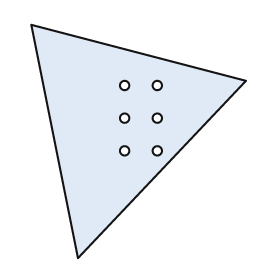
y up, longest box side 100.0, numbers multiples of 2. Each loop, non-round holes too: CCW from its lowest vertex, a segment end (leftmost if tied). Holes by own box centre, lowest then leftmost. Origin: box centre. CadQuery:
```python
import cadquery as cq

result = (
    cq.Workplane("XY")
    .moveTo(-26.0, -50.0)
    .lineTo(46.0, 26.0)
    .lineTo(-46.0, 50.0)
    .close()
    .moveTo(-6.0, -4.0)
    .circle(2.0)
    .moveTo(8.0, -4.0)
    .circle(2.0)
    .moveTo(-6.0, 10.0)
    .circle(2.0)
    .moveTo(8.0, 10.0)
    .circle(2.0)
    .moveTo(-6.0, 24.0)
    .circle(2.0)
    .moveTo(8.0, 24.0)
    .circle(2.0)
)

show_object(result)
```